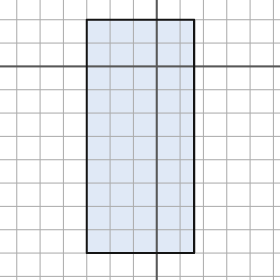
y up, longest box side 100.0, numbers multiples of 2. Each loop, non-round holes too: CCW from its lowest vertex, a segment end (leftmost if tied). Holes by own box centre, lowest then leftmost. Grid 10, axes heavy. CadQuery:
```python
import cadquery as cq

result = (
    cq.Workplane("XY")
    .moveTo(-30.0, -80.0)
    .lineTo(16.0, -80.0)
    .lineTo(16.0, 20.0)
    .lineTo(-30.0, 20.0)
    .close()
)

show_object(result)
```